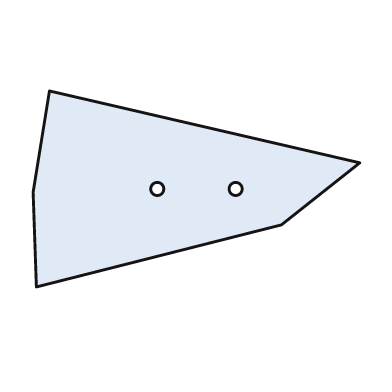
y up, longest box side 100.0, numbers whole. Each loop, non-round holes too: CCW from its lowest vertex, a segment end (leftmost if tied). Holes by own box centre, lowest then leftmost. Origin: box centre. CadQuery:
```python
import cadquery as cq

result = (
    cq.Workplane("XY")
    .moveTo(-49.0, -30.0)
    .lineTo(26.0, -11.0)
    .lineTo(50.0, 8.0)
    .lineTo(-45.0, 30.0)
    .lineTo(-50.0, -1.0)
    .close()
    .moveTo(-12.0, 0.0)
    .circle(2.0)
    .moveTo(12.0, 0.0)
    .circle(2.0)
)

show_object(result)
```